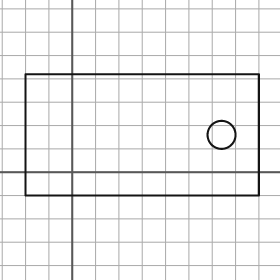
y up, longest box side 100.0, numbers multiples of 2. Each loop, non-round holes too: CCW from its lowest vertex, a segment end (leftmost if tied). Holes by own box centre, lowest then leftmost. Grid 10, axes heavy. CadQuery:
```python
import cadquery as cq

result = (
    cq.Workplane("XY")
    .moveTo(-20.0, -10.0)
    .lineTo(80.0, -10.0)
    .lineTo(80.0, 42.0)
    .lineTo(-20.0, 42.0)
    .close()
    .moveTo(64.0, 16.0)
    .circle(6.0)
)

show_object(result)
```